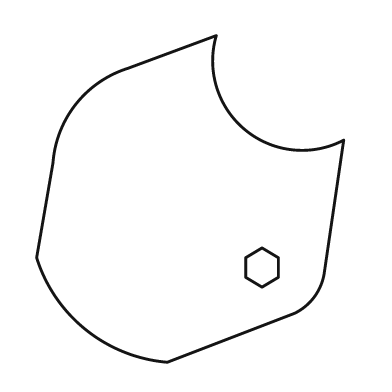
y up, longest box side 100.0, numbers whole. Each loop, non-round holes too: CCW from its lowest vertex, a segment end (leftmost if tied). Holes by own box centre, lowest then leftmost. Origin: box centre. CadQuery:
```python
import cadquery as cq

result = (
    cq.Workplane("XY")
    .moveTo(-7.0, -50.0)
    .lineTo(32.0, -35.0)
    .threePointArc((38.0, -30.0), (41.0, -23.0))
    .lineTo(47.0, 18.0)
    .threePointArc((17.0, 21.0), (8.0, 50.0))
    .lineTo(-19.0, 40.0)
    .threePointArc((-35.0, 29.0), (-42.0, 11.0))
    .lineTo(-47.0, -18.0)
    .threePointArc((-32.0, -40.0), (-7.0, -50.0))
    .close()
    .moveTo(22.0, -27.0)
    .lineTo(27.0, -24.0)
    .lineTo(27.0, -18.0)
    .lineTo(22.0, -15.0)
    .lineTo(17.0, -18.0)
    .lineTo(17.0, -24.0)
    .close()
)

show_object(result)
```